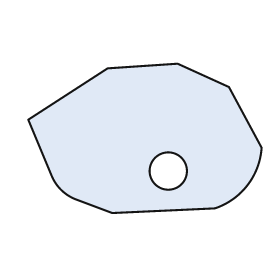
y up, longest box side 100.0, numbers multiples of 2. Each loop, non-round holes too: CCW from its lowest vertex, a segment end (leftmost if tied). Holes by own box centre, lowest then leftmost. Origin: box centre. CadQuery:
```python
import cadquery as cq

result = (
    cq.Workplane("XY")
    .moveTo(-14.0, -32.0)
    .lineTo(30.0, -30.0)
    .threePointArc((44.0, -20.0), (50.0, -4.0))
    .lineTo(36.0, 22.0)
    .lineTo(14.0, 32.0)
    .lineTo(-16.0, 30.0)
    .lineTo(-50.0, 8.0)
    .lineTo(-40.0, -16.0)
    .threePointArc((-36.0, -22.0), (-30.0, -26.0))
    .close()
    .moveTo(10.0, -14.0)
    .circle(8.0)
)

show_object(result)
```